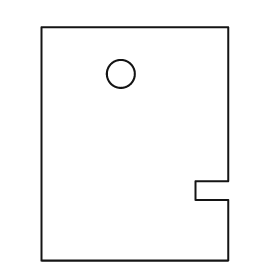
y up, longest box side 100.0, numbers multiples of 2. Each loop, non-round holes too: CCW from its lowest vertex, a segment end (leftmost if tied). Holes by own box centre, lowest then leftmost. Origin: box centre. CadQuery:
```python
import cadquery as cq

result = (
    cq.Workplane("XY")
    .moveTo(-40.0, -50.0)
    .lineTo(40.0, -50.0)
    .lineTo(40.0, -24.0)
    .lineTo(26.0, -24.0)
    .lineTo(26.0, -16.0)
    .lineTo(40.0, -16.0)
    .lineTo(40.0, 50.0)
    .lineTo(-40.0, 50.0)
    .close()
    .moveTo(-6.0, 30.0)
    .circle(6.0)
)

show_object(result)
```